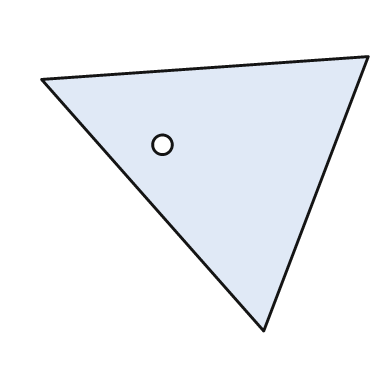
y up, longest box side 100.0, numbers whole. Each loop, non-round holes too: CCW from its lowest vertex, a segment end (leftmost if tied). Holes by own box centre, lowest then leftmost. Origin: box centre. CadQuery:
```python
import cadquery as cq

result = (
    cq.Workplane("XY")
    .moveTo(18.0, -42.0)
    .lineTo(50.0, 42.0)
    .lineTo(-50.0, 35.0)
    .close()
    .moveTo(-13.0, 15.0)
    .circle(3.0)
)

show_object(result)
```